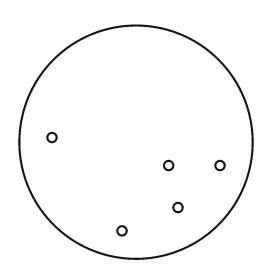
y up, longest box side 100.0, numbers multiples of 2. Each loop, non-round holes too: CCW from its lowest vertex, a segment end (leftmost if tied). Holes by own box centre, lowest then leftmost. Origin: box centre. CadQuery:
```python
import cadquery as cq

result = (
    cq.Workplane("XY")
    .moveTo(0.0, 0.0)
    .circle(50.0)
    .moveTo(-6.0, -38.0)
    .circle(2.0)
    .moveTo(18.0, -28.0)
    .circle(2.0)
    .moveTo(14.0, -10.0)
    .circle(2.0)
    .moveTo(36.0, -10.0)
    .circle(2.0)
    .moveTo(-36.0, 2.0)
    .circle(2.0)
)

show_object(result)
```